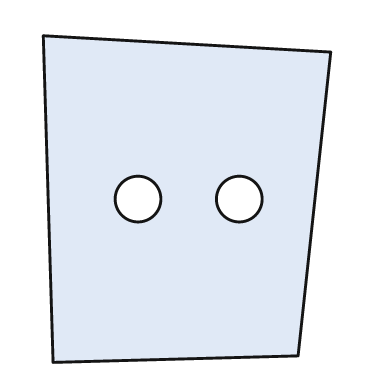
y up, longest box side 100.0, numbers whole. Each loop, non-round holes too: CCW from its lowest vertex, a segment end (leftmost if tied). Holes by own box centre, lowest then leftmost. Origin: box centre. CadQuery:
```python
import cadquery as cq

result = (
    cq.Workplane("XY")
    .moveTo(-41.0, -50.0)
    .lineTo(34.0, -48.0)
    .lineTo(44.0, 45.0)
    .lineTo(-44.0, 50.0)
    .close()
    .moveTo(-15.0, 0.0)
    .circle(7.0)
    .moveTo(16.0, 0.0)
    .circle(7.0)
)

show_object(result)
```